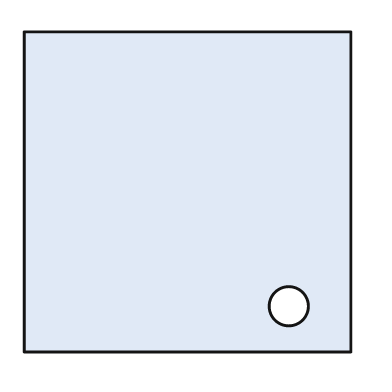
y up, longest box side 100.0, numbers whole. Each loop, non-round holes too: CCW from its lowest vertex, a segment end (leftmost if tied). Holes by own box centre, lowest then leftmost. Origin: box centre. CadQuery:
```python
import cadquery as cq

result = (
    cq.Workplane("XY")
    .moveTo(-50.0, -49.0)
    .lineTo(50.0, -49.0)
    .lineTo(50.0, 49.0)
    .lineTo(-50.0, 49.0)
    .close()
    .moveTo(31.0, -35.0)
    .circle(6.0)
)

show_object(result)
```